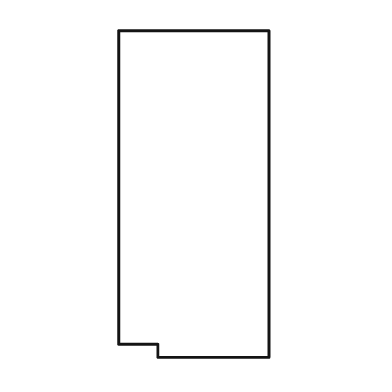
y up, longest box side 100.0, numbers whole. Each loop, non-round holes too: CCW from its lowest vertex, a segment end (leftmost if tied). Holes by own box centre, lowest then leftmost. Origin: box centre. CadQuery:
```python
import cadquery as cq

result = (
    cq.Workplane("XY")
    .moveTo(-11.0, -50.0)
    .lineTo(23.0, -50.0)
    .lineTo(23.0, 50.0)
    .lineTo(-23.0, 50.0)
    .lineTo(-23.0, -46.0)
    .lineTo(-11.0, -46.0)
    .close()
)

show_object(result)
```